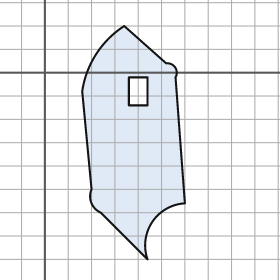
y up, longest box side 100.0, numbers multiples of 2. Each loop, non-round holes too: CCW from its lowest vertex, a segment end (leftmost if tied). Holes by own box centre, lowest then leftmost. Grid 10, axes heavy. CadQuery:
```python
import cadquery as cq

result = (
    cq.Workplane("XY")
    .moveTo(44.0, -80.0)
    .threePointArc((46.0, -64.0), (60.0, -56.0))
    .lineTo(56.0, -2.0)
    .threePointArc((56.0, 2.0), (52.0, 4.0))
    .lineTo(34.0, 20.0)
    .threePointArc((22.0, 8.0), (16.0, -8.0))
    .lineTo(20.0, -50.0)
    .threePointArc((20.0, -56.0), (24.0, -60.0))
    .close()
    .moveTo(36.0, -14.0)
    .lineTo(44.0, -14.0)
    .lineTo(44.0, -2.0)
    .lineTo(36.0, -2.0)
    .close()
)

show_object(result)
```